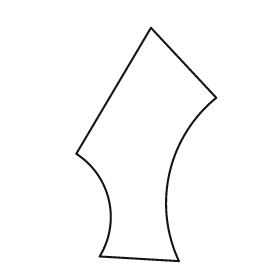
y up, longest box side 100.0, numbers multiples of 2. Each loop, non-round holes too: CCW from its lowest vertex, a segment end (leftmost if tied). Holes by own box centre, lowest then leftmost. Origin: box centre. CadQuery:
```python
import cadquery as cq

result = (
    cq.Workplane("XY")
    .moveTo(14.0, -50.0)
    .threePointArc((10.0, -12.0), (30.0, 20.0))
    .lineTo(2.0, 50.0)
    .lineTo(-30.0, -4.0)
    .threePointArc((-16.0, -24.0), (-20.0, -48.0))
    .close()
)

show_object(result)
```